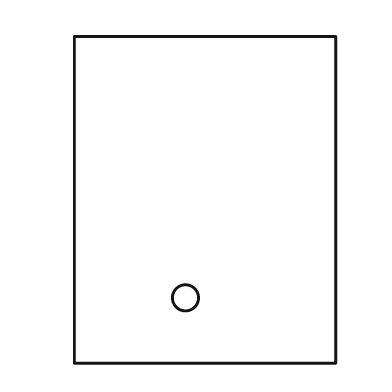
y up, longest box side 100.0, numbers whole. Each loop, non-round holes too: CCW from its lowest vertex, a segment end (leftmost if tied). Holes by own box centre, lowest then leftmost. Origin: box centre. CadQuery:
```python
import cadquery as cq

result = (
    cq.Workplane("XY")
    .moveTo(-40.0, -50.0)
    .lineTo(40.0, -50.0)
    .lineTo(40.0, 50.0)
    .lineTo(-40.0, 50.0)
    .close()
    .moveTo(-6.0, -30.0)
    .circle(4.0)
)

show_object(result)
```